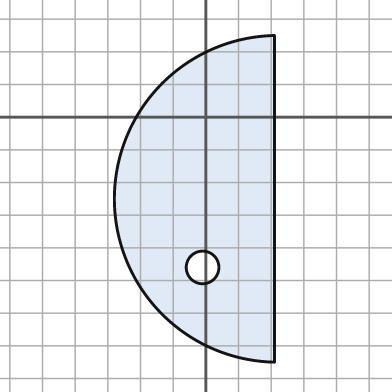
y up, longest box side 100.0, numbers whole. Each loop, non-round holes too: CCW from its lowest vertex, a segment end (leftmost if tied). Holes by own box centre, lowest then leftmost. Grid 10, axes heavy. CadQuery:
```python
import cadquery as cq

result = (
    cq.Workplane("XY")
    .moveTo(21.0, -75.0)
    .lineTo(21.0, 25.0)
    .threePointArc((-28.0, -25.0), (21.0, -75.0))
    .close()
    .moveTo(-1.0, -46.0)
    .circle(5.0)
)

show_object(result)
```